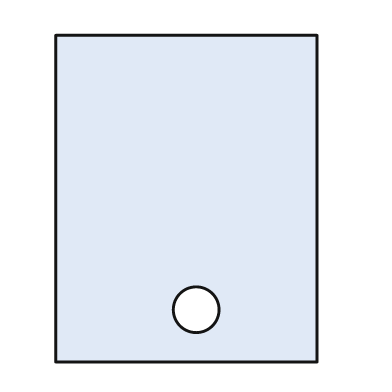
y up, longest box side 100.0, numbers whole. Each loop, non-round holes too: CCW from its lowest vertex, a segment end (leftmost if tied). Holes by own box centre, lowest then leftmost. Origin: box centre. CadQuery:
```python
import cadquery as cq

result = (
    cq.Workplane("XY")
    .moveTo(-40.0, -50.0)
    .lineTo(40.0, -50.0)
    .lineTo(40.0, 50.0)
    .lineTo(-40.0, 50.0)
    .close()
    .moveTo(3.0, -34.0)
    .circle(7.0)
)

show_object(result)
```